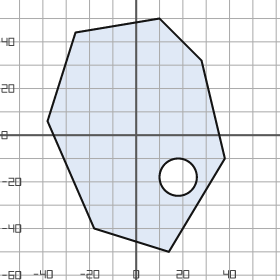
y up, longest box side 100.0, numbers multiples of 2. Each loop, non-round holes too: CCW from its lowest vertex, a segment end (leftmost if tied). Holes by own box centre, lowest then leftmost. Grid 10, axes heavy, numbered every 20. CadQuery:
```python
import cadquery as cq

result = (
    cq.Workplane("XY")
    .moveTo(14.0, -50.0)
    .lineTo(38.0, -10.0)
    .lineTo(28.0, 32.0)
    .lineTo(10.0, 50.0)
    .lineTo(-26.0, 44.0)
    .lineTo(-38.0, 6.0)
    .lineTo(-18.0, -40.0)
    .close()
    .moveTo(18.0, -18.0)
    .circle(8.0)
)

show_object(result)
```